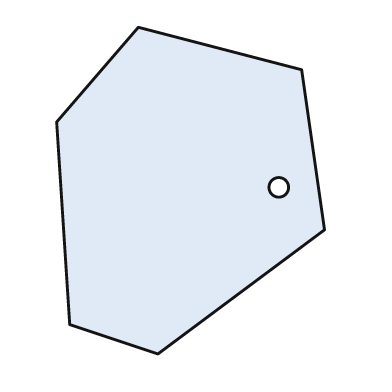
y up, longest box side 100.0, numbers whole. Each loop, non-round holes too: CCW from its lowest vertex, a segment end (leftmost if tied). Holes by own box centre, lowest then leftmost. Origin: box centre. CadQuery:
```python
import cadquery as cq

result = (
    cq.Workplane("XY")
    .moveTo(-10.0, -50.0)
    .lineTo(41.0, -12.0)
    .lineTo(34.0, 37.0)
    .lineTo(-16.0, 50.0)
    .lineTo(-41.0, 21.0)
    .lineTo(-37.0, -41.0)
    .close()
    .moveTo(27.0, 1.0)
    .circle(3.0)
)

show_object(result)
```